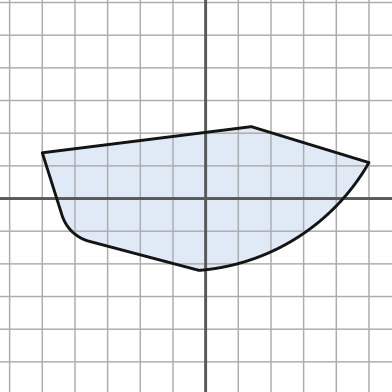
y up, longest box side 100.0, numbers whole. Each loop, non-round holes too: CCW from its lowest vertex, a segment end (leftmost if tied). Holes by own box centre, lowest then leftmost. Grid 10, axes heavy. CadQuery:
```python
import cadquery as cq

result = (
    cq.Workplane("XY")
    .moveTo(-2.0, -22.0)
    .threePointArc((28.0, -12.0), (50.0, 11.0))
    .lineTo(14.0, 22.0)
    .lineTo(-50.0, 14.0)
    .lineTo(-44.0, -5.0)
    .threePointArc((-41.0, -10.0), (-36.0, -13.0))
    .close()
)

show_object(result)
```